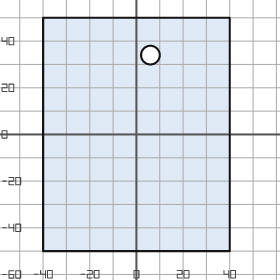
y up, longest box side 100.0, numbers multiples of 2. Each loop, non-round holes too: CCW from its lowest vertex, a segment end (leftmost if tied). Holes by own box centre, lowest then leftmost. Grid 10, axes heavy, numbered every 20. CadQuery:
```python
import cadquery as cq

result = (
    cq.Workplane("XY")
    .moveTo(-40.0, -50.0)
    .lineTo(40.0, -50.0)
    .lineTo(40.0, 50.0)
    .lineTo(-40.0, 50.0)
    .close()
    .moveTo(6.0, 34.0)
    .circle(4.0)
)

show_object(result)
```